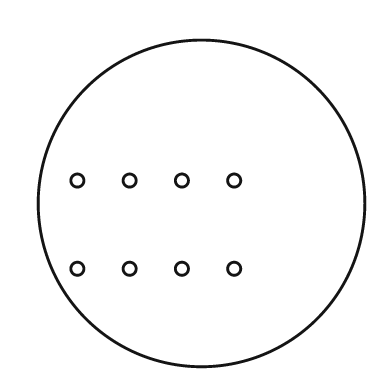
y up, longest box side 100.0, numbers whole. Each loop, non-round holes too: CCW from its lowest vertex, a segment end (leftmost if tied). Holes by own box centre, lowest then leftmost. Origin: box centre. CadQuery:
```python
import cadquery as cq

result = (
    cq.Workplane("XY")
    .moveTo(0.0, 0.0)
    .circle(50.0)
    .moveTo(-38.0, -20.0)
    .circle(2.0)
    .moveTo(-22.0, -20.0)
    .circle(2.0)
    .moveTo(-6.0, -20.0)
    .circle(2.0)
    .moveTo(10.0, -20.0)
    .circle(2.0)
    .moveTo(-38.0, 7.0)
    .circle(2.0)
    .moveTo(-22.0, 7.0)
    .circle(2.0)
    .moveTo(-6.0, 7.0)
    .circle(2.0)
    .moveTo(10.0, 7.0)
    .circle(2.0)
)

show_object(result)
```